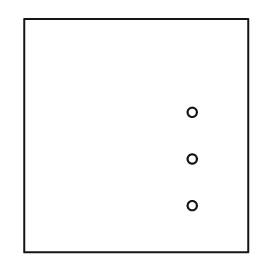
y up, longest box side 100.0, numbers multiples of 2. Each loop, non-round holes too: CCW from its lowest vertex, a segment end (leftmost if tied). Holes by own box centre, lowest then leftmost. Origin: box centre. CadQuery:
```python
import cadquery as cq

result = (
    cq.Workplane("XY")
    .moveTo(-48.0, -50.0)
    .lineTo(48.0, -50.0)
    .lineTo(48.0, 50.0)
    .lineTo(-48.0, 50.0)
    .close()
    .moveTo(24.0, -30.0)
    .circle(2.0)
    .moveTo(24.0, -10.0)
    .circle(2.0)
    .moveTo(24.0, 10.0)
    .circle(2.0)
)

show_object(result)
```